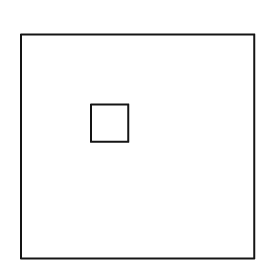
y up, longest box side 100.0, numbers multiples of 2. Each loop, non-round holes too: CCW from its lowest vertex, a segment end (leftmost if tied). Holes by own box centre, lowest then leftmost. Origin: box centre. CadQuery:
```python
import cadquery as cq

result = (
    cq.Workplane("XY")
    .moveTo(-50.0, -48.0)
    .lineTo(50.0, -48.0)
    .lineTo(50.0, 48.0)
    .lineTo(-50.0, 48.0)
    .close()
    .moveTo(-20.0, 2.0)
    .lineTo(-4.0, 2.0)
    .lineTo(-4.0, 18.0)
    .lineTo(-20.0, 18.0)
    .close()
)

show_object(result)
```